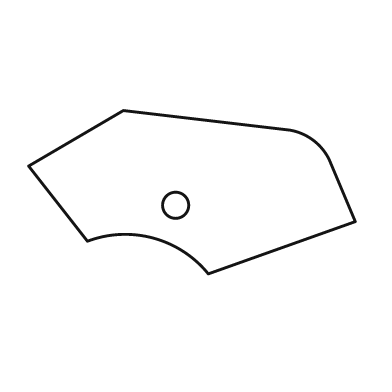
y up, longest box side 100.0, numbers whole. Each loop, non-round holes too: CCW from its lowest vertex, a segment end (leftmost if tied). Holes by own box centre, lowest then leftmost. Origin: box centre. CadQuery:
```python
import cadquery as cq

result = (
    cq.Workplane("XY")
    .moveTo(5.0, -25.0)
    .lineTo(50.0, -9.0)
    .lineTo(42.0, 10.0)
    .threePointArc((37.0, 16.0), (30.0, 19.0))
    .lineTo(-21.0, 25.0)
    .lineTo(-50.0, 8.0)
    .lineTo(-32.0, -15.0)
    .threePointArc((-12.0, -14.0), (5.0, -25.0))
    .close()
    .moveTo(-5.0, -4.0)
    .circle(4.0)
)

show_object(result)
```